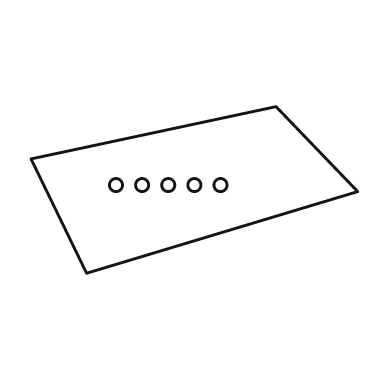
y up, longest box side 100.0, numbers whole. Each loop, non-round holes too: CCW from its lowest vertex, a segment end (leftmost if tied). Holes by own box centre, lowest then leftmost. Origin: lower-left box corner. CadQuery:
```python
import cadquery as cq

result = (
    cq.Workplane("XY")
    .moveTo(17.0, 0.0)
    .lineTo(100.0, 25.0)
    .lineTo(75.0, 51.0)
    .lineTo(0.0, 35.0)
    .close()
    .moveTo(26.0, 27.0)
    .circle(2.0)
    .moveTo(34.0, 27.0)
    .circle(2.0)
    .moveTo(42.0, 27.0)
    .circle(2.0)
    .moveTo(50.0, 27.0)
    .circle(2.0)
    .moveTo(58.0, 27.0)
    .circle(2.0)
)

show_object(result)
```